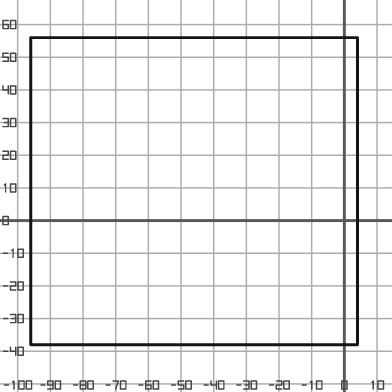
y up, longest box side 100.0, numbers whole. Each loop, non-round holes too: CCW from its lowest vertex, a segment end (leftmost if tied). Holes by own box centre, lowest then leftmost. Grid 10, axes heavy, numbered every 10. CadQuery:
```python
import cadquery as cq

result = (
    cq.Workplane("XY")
    .moveTo(-96.0, -38.0)
    .lineTo(4.0, -38.0)
    .lineTo(4.0, 56.0)
    .lineTo(-96.0, 56.0)
    .close()
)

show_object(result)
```